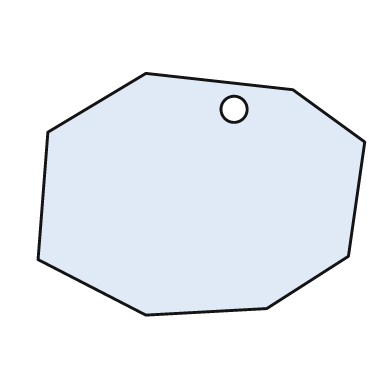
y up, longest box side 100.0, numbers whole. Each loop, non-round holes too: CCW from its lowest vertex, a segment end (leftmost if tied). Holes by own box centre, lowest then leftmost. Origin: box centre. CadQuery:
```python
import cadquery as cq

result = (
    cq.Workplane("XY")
    .moveTo(-17.0, -37.0)
    .lineTo(20.0, -35.0)
    .lineTo(45.0, -19.0)
    .lineTo(50.0, 16.0)
    .lineTo(28.0, 32.0)
    .lineTo(-17.0, 37.0)
    .lineTo(-47.0, 19.0)
    .lineTo(-50.0, -20.0)
    .close()
    .moveTo(10.0, 26.0)
    .circle(4.0)
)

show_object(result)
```